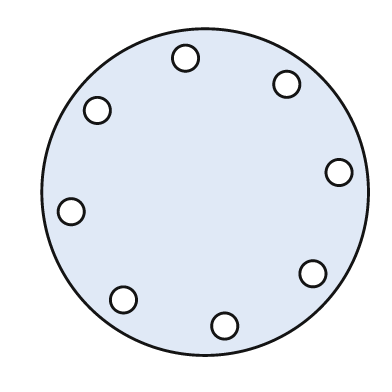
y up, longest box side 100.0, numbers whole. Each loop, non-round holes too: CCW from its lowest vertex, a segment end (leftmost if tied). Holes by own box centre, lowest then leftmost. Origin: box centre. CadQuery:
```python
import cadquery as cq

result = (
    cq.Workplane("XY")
    .moveTo(0.0, 0.0)
    .circle(50.0)
    .moveTo(6.0, -41.0)
    .circle(4.0)
    .moveTo(-25.0, -33.0)
    .circle(4.0)
    .moveTo(33.0, -25.0)
    .circle(4.0)
    .moveTo(-41.0, -6.0)
    .circle(4.0)
    .moveTo(41.0, 6.0)
    .circle(4.0)
    .moveTo(-33.0, 25.0)
    .circle(4.0)
    .moveTo(25.0, 33.0)
    .circle(4.0)
    .moveTo(-6.0, 41.0)
    .circle(4.0)
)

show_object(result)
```